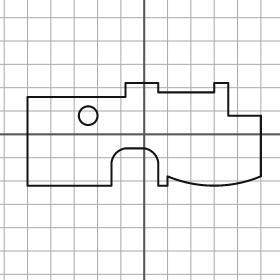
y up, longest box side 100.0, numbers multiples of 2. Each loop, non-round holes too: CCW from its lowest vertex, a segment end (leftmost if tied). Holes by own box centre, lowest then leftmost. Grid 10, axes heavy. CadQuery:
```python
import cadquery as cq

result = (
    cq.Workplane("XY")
    .moveTo(-50.0, -22.0)
    .lineTo(-14.0, -22.0)
    .lineTo(-14.0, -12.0)
    .threePointArc((-12.0, -8.0), (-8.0, -6.0))
    .lineTo(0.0, -6.0)
    .threePointArc((4.0, -8.0), (6.0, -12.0))
    .lineTo(6.0, -22.0)
    .lineTo(10.0, -22.0)
    .lineTo(10.0, -18.0)
    .threePointArc((30.0, -22.0), (50.0, -18.0))
    .lineTo(50.0, 8.0)
    .lineTo(36.0, 8.0)
    .lineTo(36.0, 22.0)
    .lineTo(30.0, 22.0)
    .lineTo(30.0, 18.0)
    .lineTo(6.0, 18.0)
    .lineTo(6.0, 22.0)
    .lineTo(-8.0, 22.0)
    .lineTo(-8.0, 16.0)
    .lineTo(-50.0, 16.0)
    .close()
    .moveTo(-24.0, 8.0)
    .circle(4.0)
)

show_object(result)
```